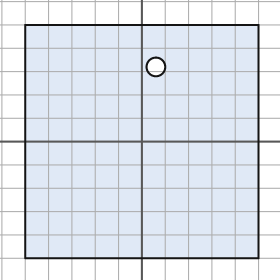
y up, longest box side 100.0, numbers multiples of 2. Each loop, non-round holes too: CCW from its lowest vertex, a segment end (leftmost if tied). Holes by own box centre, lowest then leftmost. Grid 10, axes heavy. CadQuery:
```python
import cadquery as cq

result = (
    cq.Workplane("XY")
    .moveTo(-50.0, -50.0)
    .lineTo(50.0, -50.0)
    .lineTo(50.0, 50.0)
    .lineTo(-50.0, 50.0)
    .close()
    .moveTo(6.0, 32.0)
    .circle(4.0)
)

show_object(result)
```